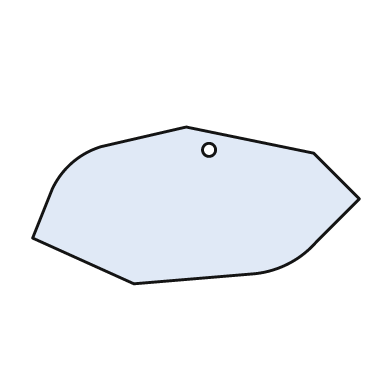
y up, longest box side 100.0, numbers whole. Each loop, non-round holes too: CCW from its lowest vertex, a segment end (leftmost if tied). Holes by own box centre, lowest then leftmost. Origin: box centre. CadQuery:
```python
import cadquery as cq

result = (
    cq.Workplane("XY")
    .moveTo(-19.0, -24.0)
    .lineTo(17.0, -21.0)
    .threePointArc((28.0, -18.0), (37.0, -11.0))
    .lineTo(50.0, 2.0)
    .lineTo(36.0, 16.0)
    .lineTo(-3.0, 24.0)
    .lineTo(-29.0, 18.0)
    .threePointArc((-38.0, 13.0), (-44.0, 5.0))
    .lineTo(-50.0, -10.0)
    .close()
    .moveTo(4.0, 17.0)
    .circle(2.0)
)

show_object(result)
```